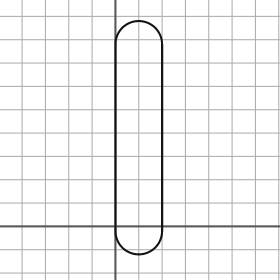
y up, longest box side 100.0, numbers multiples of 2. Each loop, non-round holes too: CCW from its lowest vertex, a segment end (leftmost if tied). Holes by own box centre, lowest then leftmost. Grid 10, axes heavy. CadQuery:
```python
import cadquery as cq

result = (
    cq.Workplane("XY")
    .moveTo(0.0, -2.0)
    .threePointArc((10.0, -12.0), (20.0, -2.0))
    .lineTo(20.0, 78.0)
    .threePointArc((10.0, 88.0), (0.0, 78.0))
    .close()
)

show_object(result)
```